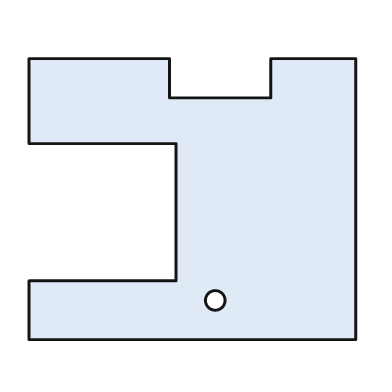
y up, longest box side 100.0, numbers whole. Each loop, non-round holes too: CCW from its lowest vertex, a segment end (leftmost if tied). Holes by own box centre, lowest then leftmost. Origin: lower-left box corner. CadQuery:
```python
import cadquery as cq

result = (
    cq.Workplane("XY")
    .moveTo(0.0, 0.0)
    .lineTo(100.0, 0.0)
    .lineTo(100.0, 86.0)
    .lineTo(74.0, 86.0)
    .lineTo(74.0, 74.0)
    .lineTo(43.0, 74.0)
    .lineTo(43.0, 86.0)
    .lineTo(0.0, 86.0)
    .lineTo(0.0, 60.0)
    .lineTo(45.0, 60.0)
    .lineTo(45.0, 18.0)
    .lineTo(0.0, 18.0)
    .close()
    .moveTo(57.0, 12.0)
    .circle(3.0)
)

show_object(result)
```